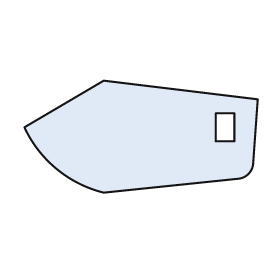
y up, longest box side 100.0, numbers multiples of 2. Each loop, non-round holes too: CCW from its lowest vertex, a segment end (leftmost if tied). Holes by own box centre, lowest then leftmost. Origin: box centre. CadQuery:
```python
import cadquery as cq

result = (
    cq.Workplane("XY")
    .moveTo(-16.0, -24.0)
    .lineTo(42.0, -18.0)
    .threePointArc((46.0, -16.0), (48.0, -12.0))
    .lineTo(50.0, 16.0)
    .lineTo(-16.0, 24.0)
    .lineTo(-50.0, 4.0)
    .threePointArc((-36.0, -14.0), (-16.0, -24.0))
    .close()
    .moveTo(32.0, -2.0)
    .lineTo(40.0, -2.0)
    .lineTo(40.0, 10.0)
    .lineTo(32.0, 10.0)
    .close()
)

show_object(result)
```